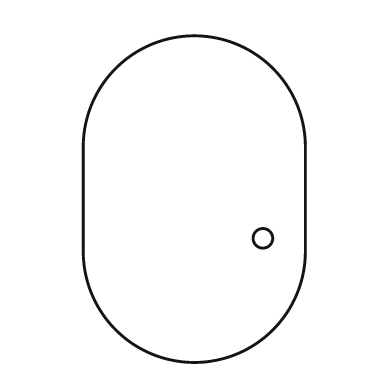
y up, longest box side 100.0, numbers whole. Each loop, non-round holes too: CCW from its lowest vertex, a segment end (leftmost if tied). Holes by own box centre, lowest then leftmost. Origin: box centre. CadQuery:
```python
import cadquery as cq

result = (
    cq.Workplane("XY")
    .moveTo(-34.0, -16.0)
    .threePointArc((0.0, -50.0), (34.0, -16.0))
    .lineTo(34.0, 16.0)
    .threePointArc((0.0, 50.0), (-34.0, 16.0))
    .close()
    .moveTo(21.0, -12.0)
    .circle(3.0)
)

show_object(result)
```